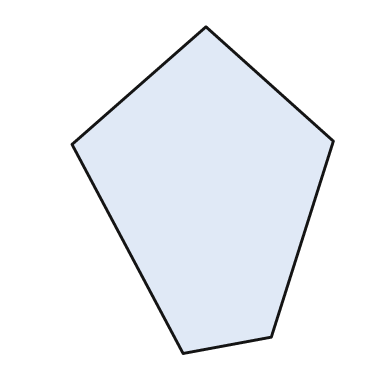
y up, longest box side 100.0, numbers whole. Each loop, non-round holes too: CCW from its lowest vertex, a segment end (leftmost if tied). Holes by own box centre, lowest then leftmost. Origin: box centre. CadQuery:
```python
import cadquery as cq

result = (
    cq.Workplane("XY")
    .moveTo(-6.0, -50.0)
    .lineTo(21.0, -45.0)
    .lineTo(40.0, 15.0)
    .lineTo(1.0, 50.0)
    .lineTo(-40.0, 14.0)
    .close()
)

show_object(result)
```